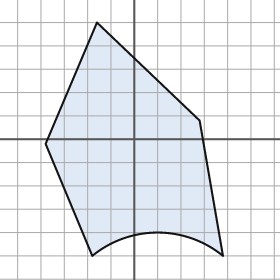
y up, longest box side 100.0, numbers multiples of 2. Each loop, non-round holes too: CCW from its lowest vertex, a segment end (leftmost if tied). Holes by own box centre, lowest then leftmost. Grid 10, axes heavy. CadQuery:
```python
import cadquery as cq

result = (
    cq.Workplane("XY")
    .moveTo(-18.0, -50.0)
    .threePointArc((10.0, -40.0), (38.0, -50.0))
    .lineTo(28.0, 8.0)
    .lineTo(-16.0, 50.0)
    .lineTo(-38.0, -2.0)
    .close()
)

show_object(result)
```